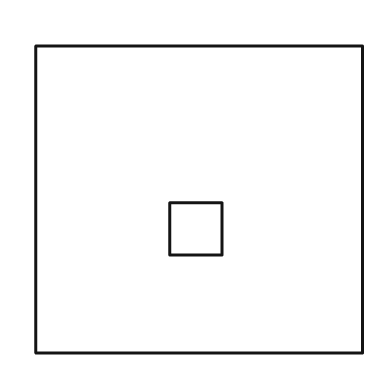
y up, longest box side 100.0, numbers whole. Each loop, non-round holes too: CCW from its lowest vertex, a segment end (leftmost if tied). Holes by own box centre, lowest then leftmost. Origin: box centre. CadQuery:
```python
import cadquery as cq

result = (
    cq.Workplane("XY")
    .moveTo(-50.0, -47.0)
    .lineTo(50.0, -47.0)
    .lineTo(50.0, 47.0)
    .lineTo(-50.0, 47.0)
    .close()
    .moveTo(-9.0, -17.0)
    .lineTo(7.0, -17.0)
    .lineTo(7.0, -1.0)
    .lineTo(-9.0, -1.0)
    .close()
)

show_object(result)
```